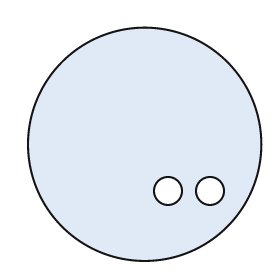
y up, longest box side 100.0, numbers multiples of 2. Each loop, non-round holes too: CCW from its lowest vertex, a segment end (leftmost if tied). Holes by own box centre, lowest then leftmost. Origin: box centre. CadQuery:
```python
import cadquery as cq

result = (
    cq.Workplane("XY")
    .moveTo(0.0, 0.0)
    .circle(50.0)
    .moveTo(10.0, -20.0)
    .circle(6.0)
    .moveTo(28.0, -20.0)
    .circle(6.0)
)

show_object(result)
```